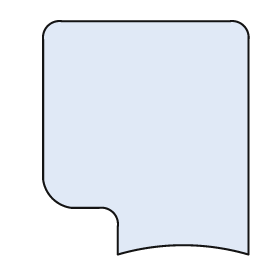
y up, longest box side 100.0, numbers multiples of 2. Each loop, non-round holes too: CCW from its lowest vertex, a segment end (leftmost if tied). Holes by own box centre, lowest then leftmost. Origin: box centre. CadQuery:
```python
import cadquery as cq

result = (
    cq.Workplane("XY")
    .moveTo(-12.0, -50.0)
    .threePointArc((16.0, -46.0), (44.0, -50.0))
    .lineTo(44.0, 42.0)
    .threePointArc((42.0, 48.0), (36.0, 50.0))
    .lineTo(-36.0, 50.0)
    .threePointArc((-42.0, 48.0), (-44.0, 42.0))
    .lineTo(-44.0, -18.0)
    .threePointArc((-40.0, -26.0), (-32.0, -30.0))
    .lineTo(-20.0, -30.0)
    .threePointArc((-14.0, -32.0), (-12.0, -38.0))
    .close()
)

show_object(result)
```